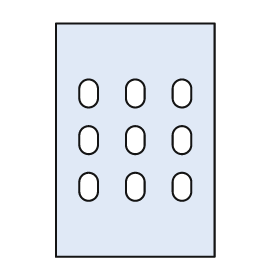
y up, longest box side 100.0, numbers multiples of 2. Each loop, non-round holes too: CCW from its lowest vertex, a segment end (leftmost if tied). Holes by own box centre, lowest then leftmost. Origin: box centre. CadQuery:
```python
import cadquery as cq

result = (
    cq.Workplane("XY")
    .moveTo(-34.0, -50.0)
    .lineTo(34.0, -50.0)
    .lineTo(34.0, 50.0)
    .lineTo(-34.0, 50.0)
    .close()
    .moveTo(-24.0, -22.0)
    .threePointArc((-20.0, -26.0), (-16.0, -22.0))
    .lineTo(-16.0, -18.0)
    .threePointArc((-20.0, -14.0), (-24.0, -18.0))
    .close()
    .moveTo(-4.0, -22.0)
    .threePointArc((0.0, -26.0), (4.0, -22.0))
    .lineTo(4.0, -18.0)
    .threePointArc((0.0, -14.0), (-4.0, -18.0))
    .close()
    .moveTo(16.0, -22.0)
    .threePointArc((20.0, -26.0), (24.0, -22.0))
    .lineTo(24.0, -18.0)
    .threePointArc((20.0, -14.0), (16.0, -18.0))
    .close()
    .moveTo(-24.0, -2.0)
    .threePointArc((-20.0, -6.0), (-16.0, -2.0))
    .lineTo(-16.0, 2.0)
    .threePointArc((-20.0, 6.0), (-24.0, 2.0))
    .close()
    .moveTo(-4.0, -2.0)
    .threePointArc((0.0, -6.0), (4.0, -2.0))
    .lineTo(4.0, 2.0)
    .threePointArc((0.0, 6.0), (-4.0, 2.0))
    .close()
    .moveTo(16.0, -2.0)
    .threePointArc((20.0, -6.0), (24.0, -2.0))
    .lineTo(24.0, 2.0)
    .threePointArc((20.0, 6.0), (16.0, 2.0))
    .close()
    .moveTo(-24.0, 18.0)
    .threePointArc((-20.0, 14.0), (-16.0, 18.0))
    .lineTo(-16.0, 22.0)
    .threePointArc((-20.0, 26.0), (-24.0, 22.0))
    .close()
    .moveTo(-4.0, 18.0)
    .threePointArc((0.0, 14.0), (4.0, 18.0))
    .lineTo(4.0, 22.0)
    .threePointArc((0.0, 26.0), (-4.0, 22.0))
    .close()
    .moveTo(16.0, 18.0)
    .threePointArc((20.0, 14.0), (24.0, 18.0))
    .lineTo(24.0, 22.0)
    .threePointArc((20.0, 26.0), (16.0, 22.0))
    .close()
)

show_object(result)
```